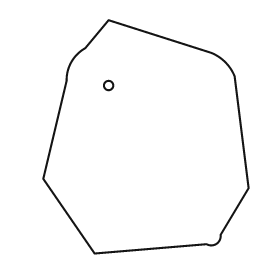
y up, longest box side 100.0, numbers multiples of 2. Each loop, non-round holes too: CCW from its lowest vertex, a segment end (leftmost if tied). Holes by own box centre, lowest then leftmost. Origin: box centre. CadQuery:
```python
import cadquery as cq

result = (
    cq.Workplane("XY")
    .moveTo(-22.0, -50.0)
    .lineTo(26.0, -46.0)
    .threePointArc((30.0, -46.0), (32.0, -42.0))
    .lineTo(44.0, -22.0)
    .lineTo(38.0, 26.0)
    .threePointArc((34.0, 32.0), (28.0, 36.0))
    .lineTo(-16.0, 50.0)
    .lineTo(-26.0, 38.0)
    .threePointArc((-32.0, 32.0), (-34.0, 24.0))
    .lineTo(-44.0, -18.0)
    .close()
    .moveTo(-16.0, 22.0)
    .circle(2.0)
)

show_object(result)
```